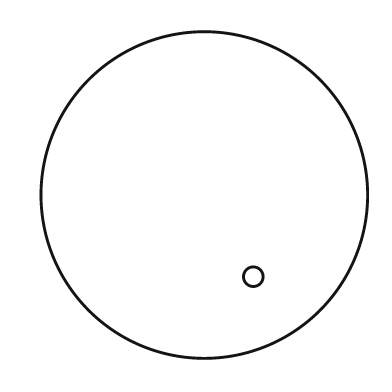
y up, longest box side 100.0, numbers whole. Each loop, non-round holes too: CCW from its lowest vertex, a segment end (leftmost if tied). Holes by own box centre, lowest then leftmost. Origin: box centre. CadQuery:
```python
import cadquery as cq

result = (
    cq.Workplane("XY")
    .moveTo(0.0, 0.0)
    .circle(50.0)
    .moveTo(15.0, -25.0)
    .circle(3.0)
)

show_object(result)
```